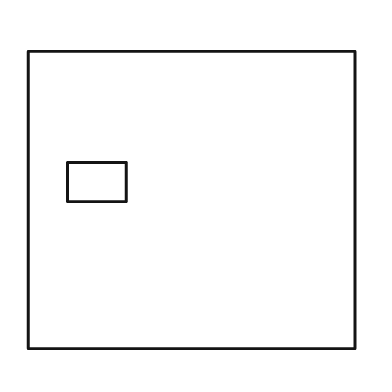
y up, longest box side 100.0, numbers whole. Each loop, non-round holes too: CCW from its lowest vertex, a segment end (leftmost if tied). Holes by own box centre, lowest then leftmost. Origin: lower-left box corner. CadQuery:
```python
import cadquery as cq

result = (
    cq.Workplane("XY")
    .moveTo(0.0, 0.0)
    .lineTo(100.0, 0.0)
    .lineTo(100.0, 91.0)
    .lineTo(0.0, 91.0)
    .close()
    .moveTo(12.0, 45.0)
    .lineTo(30.0, 45.0)
    .lineTo(30.0, 57.0)
    .lineTo(12.0, 57.0)
    .close()
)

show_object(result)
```